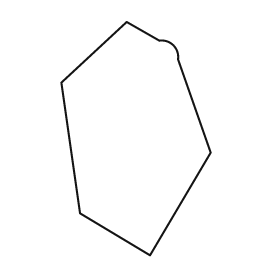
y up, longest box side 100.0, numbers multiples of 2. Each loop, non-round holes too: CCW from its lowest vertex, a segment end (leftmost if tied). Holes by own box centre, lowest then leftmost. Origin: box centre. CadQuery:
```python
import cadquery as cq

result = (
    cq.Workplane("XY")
    .moveTo(6.0, -50.0)
    .lineTo(32.0, -6.0)
    .lineTo(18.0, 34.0)
    .threePointArc((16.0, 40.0), (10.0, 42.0))
    .lineTo(-4.0, 50.0)
    .lineTo(-32.0, 24.0)
    .lineTo(-24.0, -32.0)
    .close()
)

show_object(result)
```